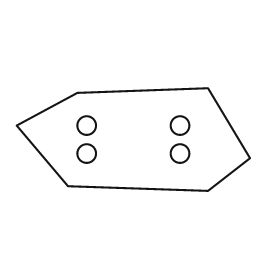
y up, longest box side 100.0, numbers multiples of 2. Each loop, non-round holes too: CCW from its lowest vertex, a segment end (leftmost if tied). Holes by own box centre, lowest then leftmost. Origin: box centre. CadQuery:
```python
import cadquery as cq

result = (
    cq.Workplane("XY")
    .moveTo(32.0, -22.0)
    .lineTo(50.0, -8.0)
    .lineTo(32.0, 22.0)
    .lineTo(-24.0, 20.0)
    .lineTo(-50.0, 6.0)
    .lineTo(-28.0, -20.0)
    .close()
    .moveTo(-20.0, -6.0)
    .circle(4.0)
    .moveTo(20.0, -6.0)
    .circle(4.0)
    .moveTo(-20.0, 6.0)
    .circle(4.0)
    .moveTo(20.0, 6.0)
    .circle(4.0)
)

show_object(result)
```